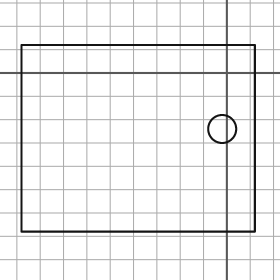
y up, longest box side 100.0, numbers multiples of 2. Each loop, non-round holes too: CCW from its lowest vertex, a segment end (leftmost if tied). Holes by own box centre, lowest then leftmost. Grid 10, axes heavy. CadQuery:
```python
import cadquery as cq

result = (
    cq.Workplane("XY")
    .moveTo(-88.0, -68.0)
    .lineTo(12.0, -68.0)
    .lineTo(12.0, 12.0)
    .lineTo(-88.0, 12.0)
    .close()
    .moveTo(-2.0, -24.0)
    .circle(6.0)
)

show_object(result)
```